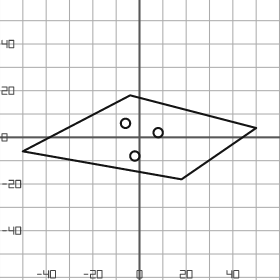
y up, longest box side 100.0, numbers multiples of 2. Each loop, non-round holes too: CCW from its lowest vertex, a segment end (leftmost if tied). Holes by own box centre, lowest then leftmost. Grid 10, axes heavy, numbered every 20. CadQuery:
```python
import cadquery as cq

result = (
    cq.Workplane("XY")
    .moveTo(18.0, -18.0)
    .lineTo(50.0, 4.0)
    .lineTo(-4.0, 18.0)
    .lineTo(-50.0, -6.0)
    .close()
    .moveTo(-2.0, -8.0)
    .circle(2.0)
    .moveTo(8.0, 2.0)
    .circle(2.0)
    .moveTo(-6.0, 6.0)
    .circle(2.0)
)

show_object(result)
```